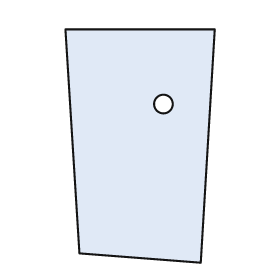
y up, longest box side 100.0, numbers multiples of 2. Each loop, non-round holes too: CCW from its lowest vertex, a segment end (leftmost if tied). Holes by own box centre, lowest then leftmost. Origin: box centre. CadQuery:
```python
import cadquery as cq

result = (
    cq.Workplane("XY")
    .moveTo(26.0, -50.0)
    .lineTo(32.0, 50.0)
    .lineTo(-32.0, 50.0)
    .lineTo(-26.0, -46.0)
    .close()
    .moveTo(10.0, 18.0)
    .circle(4.0)
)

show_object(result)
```